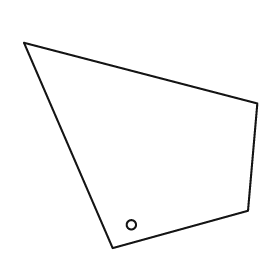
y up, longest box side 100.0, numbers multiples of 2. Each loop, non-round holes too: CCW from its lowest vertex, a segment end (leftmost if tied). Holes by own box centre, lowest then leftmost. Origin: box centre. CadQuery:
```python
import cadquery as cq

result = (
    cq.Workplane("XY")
    .moveTo(-12.0, -44.0)
    .lineTo(46.0, -28.0)
    .lineTo(50.0, 18.0)
    .lineTo(-50.0, 44.0)
    .close()
    .moveTo(-4.0, -34.0)
    .circle(2.0)
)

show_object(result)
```